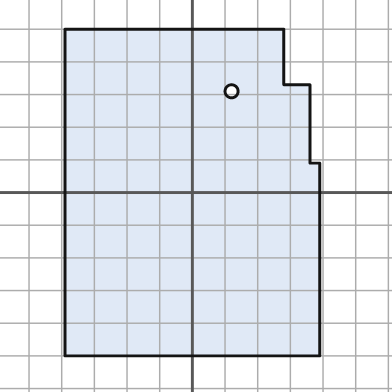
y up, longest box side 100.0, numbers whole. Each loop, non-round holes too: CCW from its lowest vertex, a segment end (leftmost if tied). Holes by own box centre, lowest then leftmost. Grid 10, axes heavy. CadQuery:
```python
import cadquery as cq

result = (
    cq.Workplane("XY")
    .moveTo(-39.0, -50.0)
    .lineTo(39.0, -50.0)
    .lineTo(39.0, 9.0)
    .lineTo(36.0, 9.0)
    .lineTo(36.0, 33.0)
    .lineTo(28.0, 33.0)
    .lineTo(28.0, 50.0)
    .lineTo(-39.0, 50.0)
    .close()
    .moveTo(12.0, 31.0)
    .circle(2.0)
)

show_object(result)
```